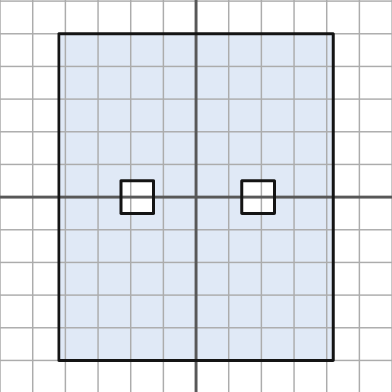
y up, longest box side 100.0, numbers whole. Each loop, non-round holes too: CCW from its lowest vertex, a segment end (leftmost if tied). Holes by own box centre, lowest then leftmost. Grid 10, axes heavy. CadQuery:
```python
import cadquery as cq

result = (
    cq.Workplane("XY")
    .moveTo(-42.0, -50.0)
    .lineTo(42.0, -50.0)
    .lineTo(42.0, 50.0)
    .lineTo(-42.0, 50.0)
    .close()
    .moveTo(-23.0, -5.0)
    .lineTo(-13.0, -5.0)
    .lineTo(-13.0, 5.0)
    .lineTo(-23.0, 5.0)
    .close()
    .moveTo(14.0, -5.0)
    .lineTo(24.0, -5.0)
    .lineTo(24.0, 5.0)
    .lineTo(14.0, 5.0)
    .close()
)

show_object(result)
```